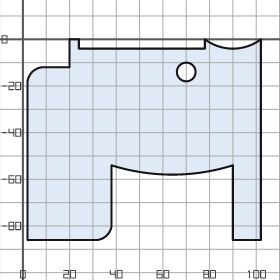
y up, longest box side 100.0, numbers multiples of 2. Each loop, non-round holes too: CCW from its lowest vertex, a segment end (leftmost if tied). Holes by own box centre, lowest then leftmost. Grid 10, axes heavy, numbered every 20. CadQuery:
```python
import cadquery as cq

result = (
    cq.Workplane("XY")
    .moveTo(2.0, -86.0)
    .lineTo(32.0, -86.0)
    .threePointArc((36.0, -84.0), (38.0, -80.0))
    .lineTo(38.0, -54.0)
    .threePointArc((64.0, -58.0), (90.0, -54.0))
    .lineTo(90.0, -86.0)
    .lineTo(102.0, -86.0)
    .lineTo(102.0, 0.0)
    .threePointArc((90.0, -4.0), (78.0, 0.0))
    .lineTo(78.0, -4.0)
    .lineTo(24.0, -4.0)
    .lineTo(24.0, 0.0)
    .lineTo(20.0, 0.0)
    .lineTo(20.0, -12.0)
    .lineTo(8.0, -12.0)
    .threePointArc((4.0, -14.0), (2.0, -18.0))
    .close()
    .moveTo(70.0, -14.0)
    .circle(4.0)
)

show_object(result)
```